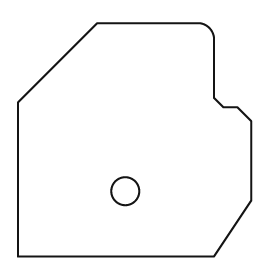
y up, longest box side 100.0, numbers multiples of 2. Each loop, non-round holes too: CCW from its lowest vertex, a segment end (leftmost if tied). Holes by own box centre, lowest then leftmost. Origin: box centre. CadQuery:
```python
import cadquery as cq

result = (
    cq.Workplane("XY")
    .moveTo(-50.0, -50.0)
    .lineTo(34.0, -50.0)
    .lineTo(50.0, -26.0)
    .lineTo(50.0, 8.0)
    .lineTo(44.0, 14.0)
    .lineTo(38.0, 14.0)
    .lineTo(34.0, 18.0)
    .lineTo(34.0, 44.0)
    .threePointArc((32.0, 48.0), (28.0, 50.0))
    .lineTo(-16.0, 50.0)
    .lineTo(-50.0, 16.0)
    .close()
    .moveTo(-4.0, -22.0)
    .circle(6.0)
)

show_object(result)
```